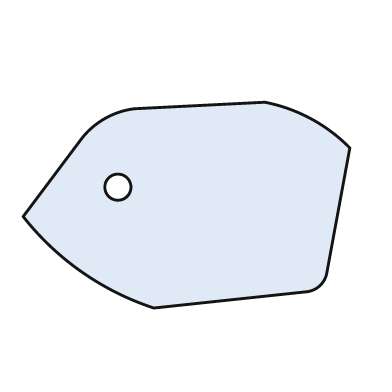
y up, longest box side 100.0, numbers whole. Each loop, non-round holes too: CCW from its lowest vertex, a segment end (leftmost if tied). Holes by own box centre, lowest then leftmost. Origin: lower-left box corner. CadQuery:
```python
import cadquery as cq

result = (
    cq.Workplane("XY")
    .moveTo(40.0, 0.0)
    .lineTo(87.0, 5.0)
    .threePointArc((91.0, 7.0), (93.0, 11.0))
    .lineTo(100.0, 49.0)
    .threePointArc((88.0, 58.0), (74.0, 63.0))
    .lineTo(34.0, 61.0)
    .threePointArc((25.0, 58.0), (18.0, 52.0))
    .lineTo(0.0, 28.0)
    .threePointArc((18.0, 11.0), (40.0, 0.0))
    .close()
    .moveTo(29.0, 37.0)
    .circle(4.0)
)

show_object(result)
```